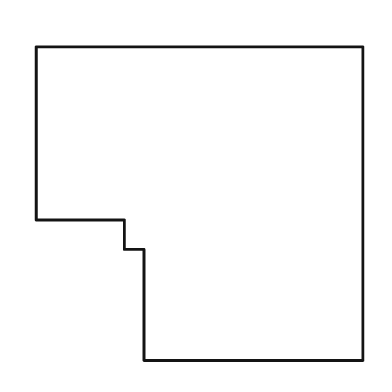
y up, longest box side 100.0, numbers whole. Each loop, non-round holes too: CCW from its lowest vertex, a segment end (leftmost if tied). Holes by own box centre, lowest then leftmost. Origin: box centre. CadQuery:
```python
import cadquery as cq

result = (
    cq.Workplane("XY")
    .moveTo(-17.0, -48.0)
    .lineTo(50.0, -48.0)
    .lineTo(50.0, 48.0)
    .lineTo(-50.0, 48.0)
    .lineTo(-50.0, -5.0)
    .lineTo(-23.0, -5.0)
    .lineTo(-23.0, -14.0)
    .lineTo(-17.0, -14.0)
    .close()
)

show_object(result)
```